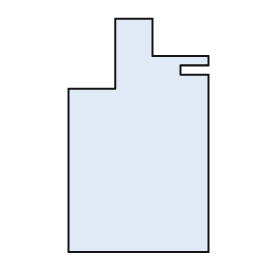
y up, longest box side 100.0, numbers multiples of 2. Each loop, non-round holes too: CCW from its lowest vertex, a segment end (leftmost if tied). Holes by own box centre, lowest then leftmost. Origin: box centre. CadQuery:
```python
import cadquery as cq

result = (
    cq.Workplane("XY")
    .moveTo(-30.0, -50.0)
    .lineTo(30.0, -50.0)
    .lineTo(30.0, 26.0)
    .lineTo(18.0, 26.0)
    .lineTo(18.0, 30.0)
    .lineTo(30.0, 30.0)
    .lineTo(30.0, 34.0)
    .lineTo(6.0, 34.0)
    .lineTo(6.0, 50.0)
    .lineTo(-10.0, 50.0)
    .lineTo(-10.0, 20.0)
    .lineTo(-30.0, 20.0)
    .close()
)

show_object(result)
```